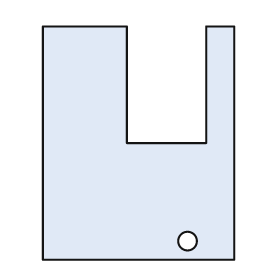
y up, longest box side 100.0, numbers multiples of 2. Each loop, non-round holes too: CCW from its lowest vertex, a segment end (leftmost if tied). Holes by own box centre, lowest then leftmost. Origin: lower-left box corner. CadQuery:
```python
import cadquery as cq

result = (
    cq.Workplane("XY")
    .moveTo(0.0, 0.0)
    .lineTo(82.0, 0.0)
    .lineTo(82.0, 100.0)
    .lineTo(70.0, 100.0)
    .lineTo(70.0, 50.0)
    .lineTo(36.0, 50.0)
    .lineTo(36.0, 100.0)
    .lineTo(0.0, 100.0)
    .close()
    .moveTo(62.0, 8.0)
    .circle(4.0)
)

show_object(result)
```